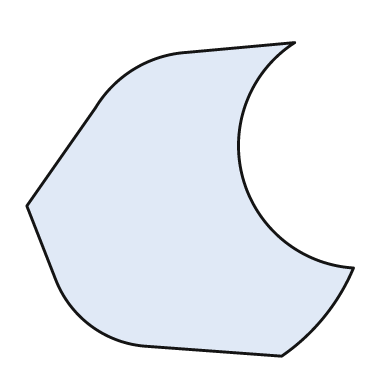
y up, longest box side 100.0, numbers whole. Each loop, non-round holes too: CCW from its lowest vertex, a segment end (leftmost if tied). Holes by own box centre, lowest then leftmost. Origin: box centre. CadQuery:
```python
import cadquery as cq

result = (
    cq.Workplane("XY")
    .moveTo(28.0, -48.0)
    .threePointArc((41.0, -36.0), (50.0, -21.0))
    .threePointArc((16.0, 7.0), (32.0, 48.0))
    .lineTo(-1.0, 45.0)
    .threePointArc((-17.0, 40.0), (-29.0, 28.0))
    .lineTo(-50.0, -2.0)
    .lineTo(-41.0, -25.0)
    .threePointArc((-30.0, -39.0), (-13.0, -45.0))
    .close()
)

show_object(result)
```